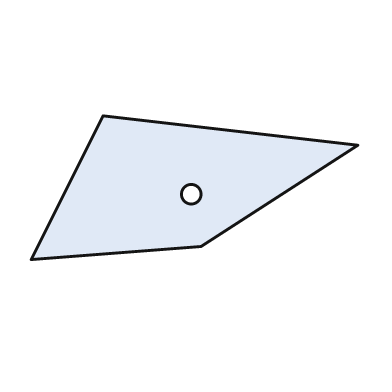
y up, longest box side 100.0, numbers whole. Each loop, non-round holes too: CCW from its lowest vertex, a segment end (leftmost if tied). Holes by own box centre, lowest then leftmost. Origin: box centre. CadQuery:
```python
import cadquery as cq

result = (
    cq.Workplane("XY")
    .moveTo(-50.0, -22.0)
    .lineTo(2.0, -18.0)
    .lineTo(50.0, 13.0)
    .lineTo(-28.0, 22.0)
    .close()
    .moveTo(-1.0, -2.0)
    .circle(3.0)
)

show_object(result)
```